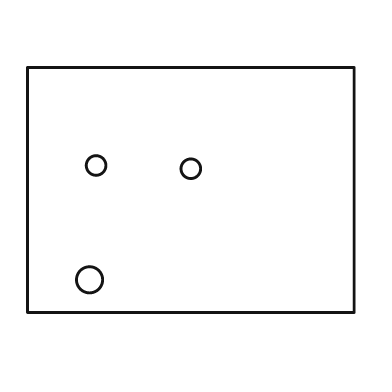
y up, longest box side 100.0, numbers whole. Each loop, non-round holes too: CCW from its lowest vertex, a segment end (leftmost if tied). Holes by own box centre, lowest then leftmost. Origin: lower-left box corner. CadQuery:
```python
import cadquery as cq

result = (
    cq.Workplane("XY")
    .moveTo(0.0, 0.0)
    .lineTo(100.0, 0.0)
    .lineTo(100.0, 75.0)
    .lineTo(0.0, 75.0)
    .close()
    .moveTo(19.0, 10.0)
    .circle(4.0)
    .moveTo(50.0, 44.0)
    .circle(3.0)
    .moveTo(21.0, 45.0)
    .circle(3.0)
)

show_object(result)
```